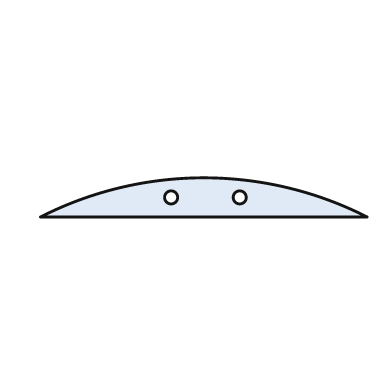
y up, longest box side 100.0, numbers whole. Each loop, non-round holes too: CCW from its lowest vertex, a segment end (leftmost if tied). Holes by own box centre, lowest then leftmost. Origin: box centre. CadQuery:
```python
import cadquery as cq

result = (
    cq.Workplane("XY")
    .moveTo(-50.0, -6.0)
    .lineTo(50.0, -6.0)
    .threePointArc((0.0, 6.0), (-50.0, -6.0))
    .close()
    .moveTo(-10.0, 0.0)
    .circle(2.0)
    .moveTo(11.0, 0.0)
    .circle(2.0)
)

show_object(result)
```